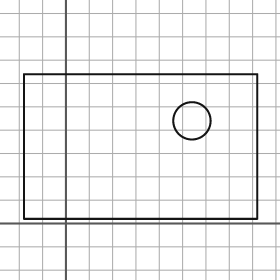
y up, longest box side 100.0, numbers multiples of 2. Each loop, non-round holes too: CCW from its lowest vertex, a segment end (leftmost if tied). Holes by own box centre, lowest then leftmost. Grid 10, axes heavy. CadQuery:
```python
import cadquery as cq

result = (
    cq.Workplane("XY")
    .moveTo(-18.0, 2.0)
    .lineTo(82.0, 2.0)
    .lineTo(82.0, 64.0)
    .lineTo(-18.0, 64.0)
    .close()
    .moveTo(54.0, 44.0)
    .circle(8.0)
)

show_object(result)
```